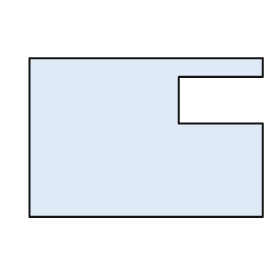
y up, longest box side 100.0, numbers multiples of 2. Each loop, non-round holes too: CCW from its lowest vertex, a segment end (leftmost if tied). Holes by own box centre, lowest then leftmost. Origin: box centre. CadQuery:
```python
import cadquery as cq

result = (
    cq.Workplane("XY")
    .moveTo(-50.0, -34.0)
    .lineTo(50.0, -34.0)
    .lineTo(50.0, 6.0)
    .lineTo(14.0, 6.0)
    .lineTo(14.0, 26.0)
    .lineTo(50.0, 26.0)
    .lineTo(50.0, 34.0)
    .lineTo(-50.0, 34.0)
    .close()
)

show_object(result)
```